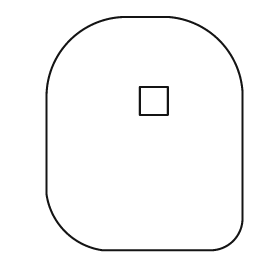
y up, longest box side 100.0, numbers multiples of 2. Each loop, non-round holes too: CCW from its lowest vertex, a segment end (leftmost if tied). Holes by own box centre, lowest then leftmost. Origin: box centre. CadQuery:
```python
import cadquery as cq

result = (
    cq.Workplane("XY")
    .moveTo(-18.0, -50.0)
    .lineTo(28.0, -50.0)
    .threePointArc((38.0, -46.0), (42.0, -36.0))
    .lineTo(42.0, 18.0)
    .threePointArc((32.0, 40.0), (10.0, 50.0))
    .lineTo(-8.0, 50.0)
    .threePointArc((-32.0, 40.0), (-42.0, 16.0))
    .lineTo(-42.0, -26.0)
    .threePointArc((-34.0, -42.0), (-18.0, -50.0))
    .close()
    .moveTo(-2.0, 8.0)
    .lineTo(10.0, 8.0)
    .lineTo(10.0, 20.0)
    .lineTo(-2.0, 20.0)
    .close()
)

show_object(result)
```